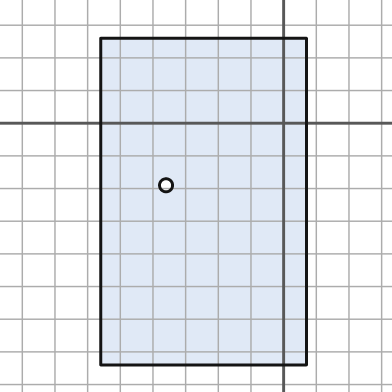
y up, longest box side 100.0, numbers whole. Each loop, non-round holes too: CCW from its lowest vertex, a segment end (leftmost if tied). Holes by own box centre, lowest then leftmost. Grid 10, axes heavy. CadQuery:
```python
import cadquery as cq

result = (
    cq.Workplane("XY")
    .moveTo(-56.0, -74.0)
    .lineTo(7.0, -74.0)
    .lineTo(7.0, 26.0)
    .lineTo(-56.0, 26.0)
    .close()
    .moveTo(-36.0, -19.0)
    .circle(2.0)
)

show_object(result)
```